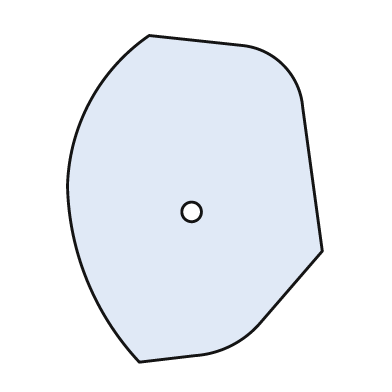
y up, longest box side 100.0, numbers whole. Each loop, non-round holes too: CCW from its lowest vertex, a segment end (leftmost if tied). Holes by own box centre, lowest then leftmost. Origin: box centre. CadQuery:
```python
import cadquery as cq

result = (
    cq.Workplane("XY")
    .moveTo(-17.0, -50.0)
    .lineTo(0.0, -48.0)
    .threePointArc((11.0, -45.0), (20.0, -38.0))
    .lineTo(39.0, -16.0)
    .lineTo(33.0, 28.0)
    .threePointArc((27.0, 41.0), (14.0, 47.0))
    .lineTo(-14.0, 50.0)
    .threePointArc((-32.0, 30.0), (-39.0, 4.0))
    .threePointArc((-33.0, -25.0), (-17.0, -50.0))
    .close()
    .moveTo(-1.0, -4.0)
    .circle(3.0)
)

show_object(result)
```